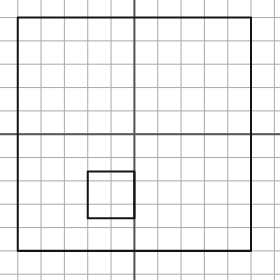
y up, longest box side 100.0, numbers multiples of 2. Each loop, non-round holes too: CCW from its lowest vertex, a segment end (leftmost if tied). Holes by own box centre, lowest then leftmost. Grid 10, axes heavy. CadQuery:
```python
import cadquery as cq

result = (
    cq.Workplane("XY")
    .moveTo(-50.0, -50.0)
    .lineTo(50.0, -50.0)
    .lineTo(50.0, 50.0)
    .lineTo(-50.0, 50.0)
    .close()
    .moveTo(-20.0, -36.0)
    .lineTo(0.0, -36.0)
    .lineTo(0.0, -16.0)
    .lineTo(-20.0, -16.0)
    .close()
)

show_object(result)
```